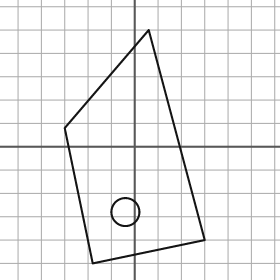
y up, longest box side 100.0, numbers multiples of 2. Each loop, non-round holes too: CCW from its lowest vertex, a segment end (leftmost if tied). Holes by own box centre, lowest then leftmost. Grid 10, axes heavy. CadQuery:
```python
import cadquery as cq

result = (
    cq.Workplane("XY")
    .moveTo(-18.0, -50.0)
    .lineTo(30.0, -40.0)
    .lineTo(6.0, 50.0)
    .lineTo(-30.0, 8.0)
    .close()
    .moveTo(-4.0, -28.0)
    .circle(6.0)
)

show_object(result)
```